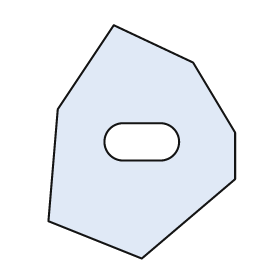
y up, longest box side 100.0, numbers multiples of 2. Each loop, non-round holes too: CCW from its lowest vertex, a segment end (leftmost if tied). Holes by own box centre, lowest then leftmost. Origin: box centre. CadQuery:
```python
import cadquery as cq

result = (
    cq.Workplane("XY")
    .moveTo(0.0, -50.0)
    .lineTo(40.0, -16.0)
    .lineTo(40.0, 4.0)
    .lineTo(22.0, 34.0)
    .lineTo(-12.0, 50.0)
    .lineTo(-36.0, 14.0)
    .lineTo(-40.0, -34.0)
    .close()
    .moveTo(-8.0, -8.0)
    .lineTo(8.0, -8.0)
    .threePointArc((16.0, 0.0), (8.0, 8.0))
    .lineTo(-8.0, 8.0)
    .threePointArc((-16.0, 0.0), (-8.0, -8.0))
    .close()
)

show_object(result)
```